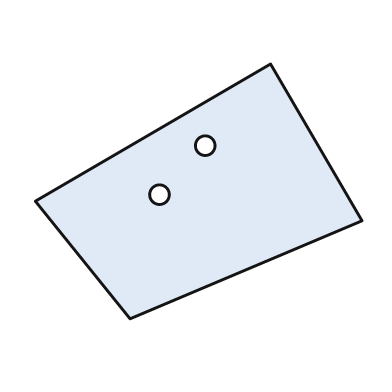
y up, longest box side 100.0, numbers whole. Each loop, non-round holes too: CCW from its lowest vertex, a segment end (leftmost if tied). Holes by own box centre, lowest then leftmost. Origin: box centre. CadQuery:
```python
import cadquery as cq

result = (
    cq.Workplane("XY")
    .moveTo(-21.0, -39.0)
    .lineTo(50.0, -9.0)
    .lineTo(22.0, 39.0)
    .lineTo(-50.0, -3.0)
    .close()
    .moveTo(-12.0, -1.0)
    .circle(3.0)
    .moveTo(2.0, 14.0)
    .circle(3.0)
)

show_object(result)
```